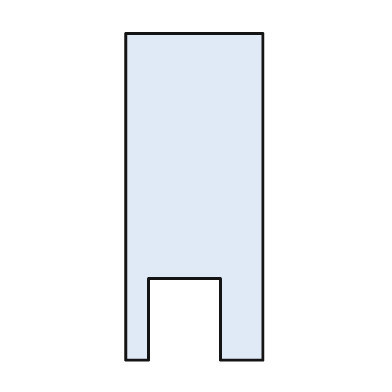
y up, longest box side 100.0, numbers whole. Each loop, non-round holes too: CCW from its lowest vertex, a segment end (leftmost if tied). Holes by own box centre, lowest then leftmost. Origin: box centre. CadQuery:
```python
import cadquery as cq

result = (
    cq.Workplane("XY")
    .moveTo(-21.0, -50.0)
    .lineTo(-14.0, -50.0)
    .lineTo(-14.0, -25.0)
    .lineTo(8.0, -25.0)
    .lineTo(8.0, -50.0)
    .lineTo(21.0, -50.0)
    .lineTo(21.0, 50.0)
    .lineTo(-21.0, 50.0)
    .close()
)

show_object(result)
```